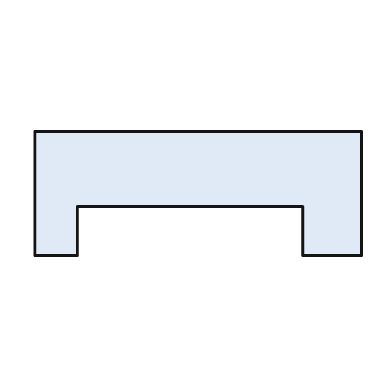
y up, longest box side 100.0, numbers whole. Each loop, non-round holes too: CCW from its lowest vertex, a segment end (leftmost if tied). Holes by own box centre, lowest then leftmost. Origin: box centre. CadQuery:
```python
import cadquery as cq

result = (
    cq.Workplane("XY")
    .moveTo(-50.0, -19.0)
    .lineTo(-37.0, -19.0)
    .lineTo(-37.0, -4.0)
    .lineTo(32.0, -4.0)
    .lineTo(32.0, -19.0)
    .lineTo(50.0, -19.0)
    .lineTo(50.0, 19.0)
    .lineTo(-50.0, 19.0)
    .close()
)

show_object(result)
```